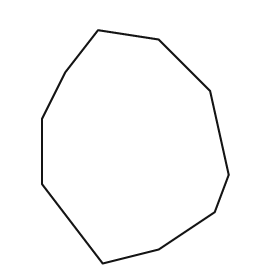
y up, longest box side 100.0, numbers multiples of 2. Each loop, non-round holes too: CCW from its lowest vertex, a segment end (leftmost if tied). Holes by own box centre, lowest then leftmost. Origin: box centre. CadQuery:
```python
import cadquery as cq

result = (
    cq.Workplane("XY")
    .moveTo(-14.0, -50.0)
    .lineTo(10.0, -44.0)
    .lineTo(34.0, -28.0)
    .lineTo(40.0, -12.0)
    .lineTo(32.0, 24.0)
    .lineTo(10.0, 46.0)
    .lineTo(-16.0, 50.0)
    .lineTo(-30.0, 32.0)
    .lineTo(-40.0, 12.0)
    .lineTo(-40.0, -16.0)
    .close()
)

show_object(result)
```